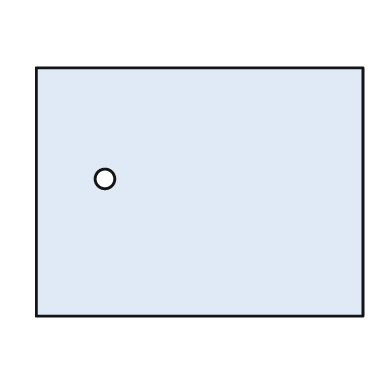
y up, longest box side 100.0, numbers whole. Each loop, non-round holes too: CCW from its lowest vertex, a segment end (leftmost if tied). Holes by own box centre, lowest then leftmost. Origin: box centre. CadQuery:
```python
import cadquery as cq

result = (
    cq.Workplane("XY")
    .moveTo(-50.0, -38.0)
    .lineTo(50.0, -38.0)
    .lineTo(50.0, 38.0)
    .lineTo(-50.0, 38.0)
    .close()
    .moveTo(-29.0, 4.0)
    .circle(3.0)
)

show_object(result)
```